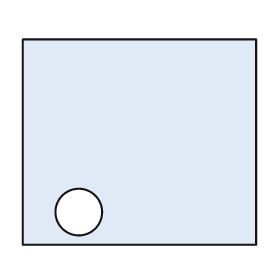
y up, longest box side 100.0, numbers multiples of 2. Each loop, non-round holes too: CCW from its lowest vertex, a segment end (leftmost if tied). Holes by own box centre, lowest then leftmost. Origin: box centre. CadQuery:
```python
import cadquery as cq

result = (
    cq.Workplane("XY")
    .moveTo(-50.0, -44.0)
    .lineTo(50.0, -44.0)
    .lineTo(50.0, 44.0)
    .lineTo(-50.0, 44.0)
    .close()
    .moveTo(-26.0, -30.0)
    .circle(10.0)
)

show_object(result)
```